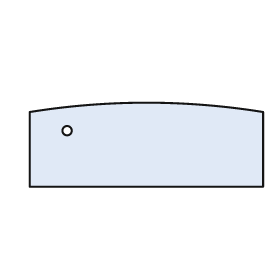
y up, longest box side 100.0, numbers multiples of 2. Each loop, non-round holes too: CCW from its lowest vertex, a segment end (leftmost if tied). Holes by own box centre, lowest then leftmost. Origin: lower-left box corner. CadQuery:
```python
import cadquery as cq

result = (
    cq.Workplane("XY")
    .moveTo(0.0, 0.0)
    .lineTo(100.0, 0.0)
    .lineTo(100.0, 32.0)
    .threePointArc((50.0, 36.0), (0.0, 32.0))
    .close()
    .moveTo(16.0, 24.0)
    .circle(2.0)
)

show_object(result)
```